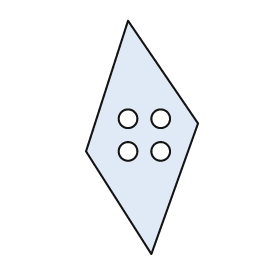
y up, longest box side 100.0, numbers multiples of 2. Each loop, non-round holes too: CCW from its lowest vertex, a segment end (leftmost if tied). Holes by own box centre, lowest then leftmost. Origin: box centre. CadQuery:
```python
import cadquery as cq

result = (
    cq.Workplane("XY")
    .moveTo(4.0, -50.0)
    .lineTo(24.0, 6.0)
    .lineTo(-6.0, 50.0)
    .lineTo(-24.0, -6.0)
    .close()
    .moveTo(-6.0, -6.0)
    .circle(4.0)
    .moveTo(8.0, -6.0)
    .circle(4.0)
    .moveTo(-6.0, 8.0)
    .circle(4.0)
    .moveTo(8.0, 8.0)
    .circle(4.0)
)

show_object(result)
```